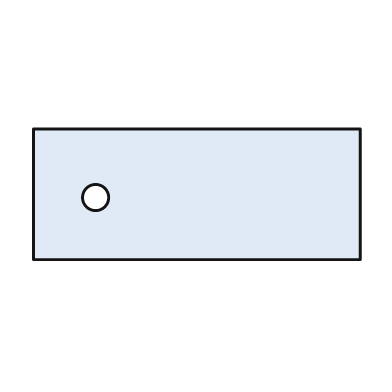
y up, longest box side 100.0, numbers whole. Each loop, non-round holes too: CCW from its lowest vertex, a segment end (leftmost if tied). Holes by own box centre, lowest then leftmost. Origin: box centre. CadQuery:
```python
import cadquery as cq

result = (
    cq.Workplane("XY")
    .moveTo(-50.0, -20.0)
    .lineTo(50.0, -20.0)
    .lineTo(50.0, 20.0)
    .lineTo(-50.0, 20.0)
    .close()
    .moveTo(-31.0, -1.0)
    .circle(4.0)
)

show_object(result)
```